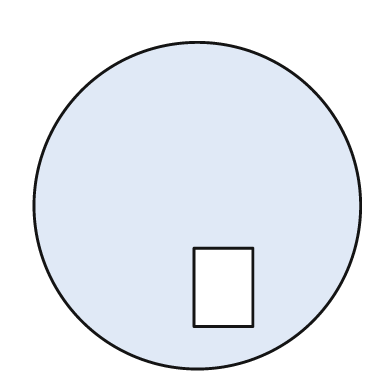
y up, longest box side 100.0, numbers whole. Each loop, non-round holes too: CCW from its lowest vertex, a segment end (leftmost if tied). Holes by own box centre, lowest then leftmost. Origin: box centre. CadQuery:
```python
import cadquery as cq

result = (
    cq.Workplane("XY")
    .moveTo(0.0, 0.0)
    .circle(50.0)
    .moveTo(-1.0, -37.0)
    .lineTo(17.0, -37.0)
    .lineTo(17.0, -13.0)
    .lineTo(-1.0, -13.0)
    .close()
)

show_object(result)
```